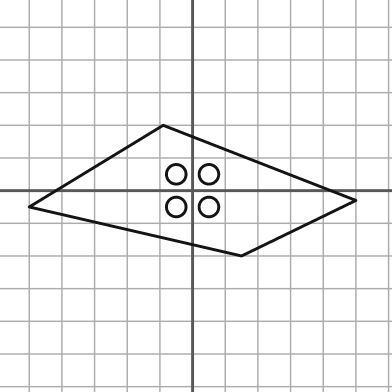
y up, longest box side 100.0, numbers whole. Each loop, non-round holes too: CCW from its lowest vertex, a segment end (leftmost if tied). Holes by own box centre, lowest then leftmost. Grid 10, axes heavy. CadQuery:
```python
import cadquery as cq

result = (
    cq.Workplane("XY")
    .moveTo(15.0, -20.0)
    .lineTo(50.0, -3.0)
    .lineTo(-9.0, 20.0)
    .lineTo(-50.0, -5.0)
    .close()
    .moveTo(-5.0, -5.0)
    .circle(3.0)
    .moveTo(5.0, -5.0)
    .circle(3.0)
    .moveTo(-5.0, 5.0)
    .circle(3.0)
    .moveTo(5.0, 5.0)
    .circle(3.0)
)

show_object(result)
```